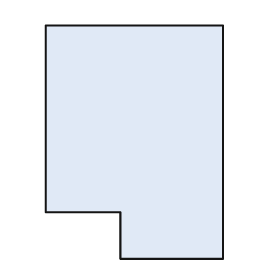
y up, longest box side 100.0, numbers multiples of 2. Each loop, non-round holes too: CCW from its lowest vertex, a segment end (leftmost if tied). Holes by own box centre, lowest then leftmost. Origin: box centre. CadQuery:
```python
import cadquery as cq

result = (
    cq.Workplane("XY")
    .moveTo(-6.0, -50.0)
    .lineTo(38.0, -50.0)
    .lineTo(38.0, 50.0)
    .lineTo(-38.0, 50.0)
    .lineTo(-38.0, -30.0)
    .lineTo(-6.0, -30.0)
    .close()
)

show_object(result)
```